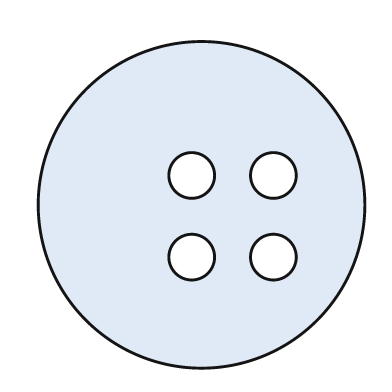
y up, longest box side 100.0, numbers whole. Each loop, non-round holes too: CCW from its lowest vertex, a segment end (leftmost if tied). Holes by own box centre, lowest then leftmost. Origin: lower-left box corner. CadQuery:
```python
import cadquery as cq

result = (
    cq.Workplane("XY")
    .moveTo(50.0, 50.0)
    .circle(50.0)
    .moveTo(47.0, 34.0)
    .circle(7.0)
    .moveTo(72.0, 34.0)
    .circle(7.0)
    .moveTo(47.0, 59.0)
    .circle(7.0)
    .moveTo(72.0, 59.0)
    .circle(7.0)
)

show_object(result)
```